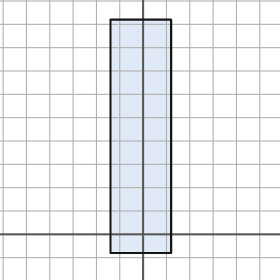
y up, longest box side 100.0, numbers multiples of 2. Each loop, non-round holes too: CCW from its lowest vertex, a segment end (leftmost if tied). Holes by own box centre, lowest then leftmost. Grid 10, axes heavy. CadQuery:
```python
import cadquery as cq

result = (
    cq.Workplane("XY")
    .moveTo(-14.0, -8.0)
    .lineTo(12.0, -8.0)
    .lineTo(12.0, 92.0)
    .lineTo(-14.0, 92.0)
    .close()
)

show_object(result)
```